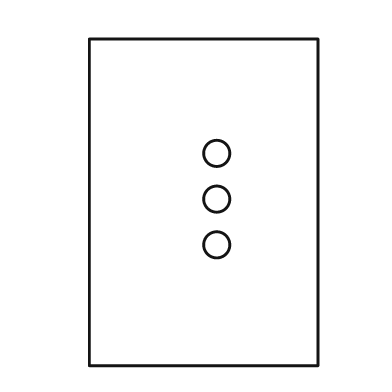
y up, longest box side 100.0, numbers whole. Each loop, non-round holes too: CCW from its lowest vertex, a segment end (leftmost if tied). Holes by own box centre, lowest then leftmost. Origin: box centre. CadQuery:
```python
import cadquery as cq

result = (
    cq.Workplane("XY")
    .moveTo(-35.0, -50.0)
    .lineTo(35.0, -50.0)
    .lineTo(35.0, 50.0)
    .lineTo(-35.0, 50.0)
    .close()
    .moveTo(4.0, -13.0)
    .circle(4.0)
    .moveTo(4.0, 1.0)
    .circle(4.0)
    .moveTo(4.0, 15.0)
    .circle(4.0)
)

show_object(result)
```